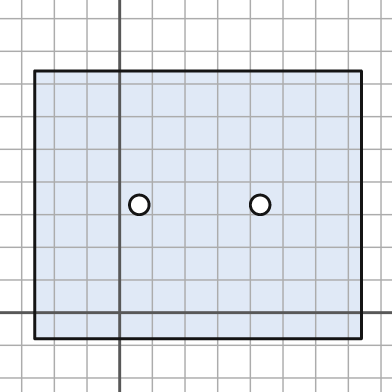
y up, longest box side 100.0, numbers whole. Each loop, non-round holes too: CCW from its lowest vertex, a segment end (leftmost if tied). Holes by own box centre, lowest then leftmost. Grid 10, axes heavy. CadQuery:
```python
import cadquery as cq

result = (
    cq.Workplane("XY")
    .moveTo(-26.0, -8.0)
    .lineTo(74.0, -8.0)
    .lineTo(74.0, 74.0)
    .lineTo(-26.0, 74.0)
    .close()
    .moveTo(6.0, 33.0)
    .circle(3.0)
    .moveTo(43.0, 33.0)
    .circle(3.0)
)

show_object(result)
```